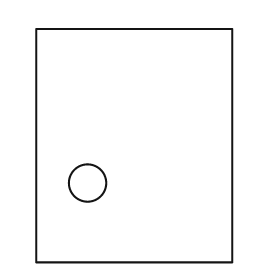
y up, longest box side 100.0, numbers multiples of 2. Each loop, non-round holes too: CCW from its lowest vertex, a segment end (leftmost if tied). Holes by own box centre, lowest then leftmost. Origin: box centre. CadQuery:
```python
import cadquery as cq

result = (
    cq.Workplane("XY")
    .moveTo(-42.0, -50.0)
    .lineTo(42.0, -50.0)
    .lineTo(42.0, 50.0)
    .lineTo(-42.0, 50.0)
    .close()
    .moveTo(-20.0, -16.0)
    .circle(8.0)
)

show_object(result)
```